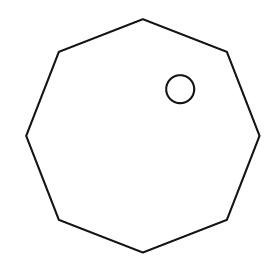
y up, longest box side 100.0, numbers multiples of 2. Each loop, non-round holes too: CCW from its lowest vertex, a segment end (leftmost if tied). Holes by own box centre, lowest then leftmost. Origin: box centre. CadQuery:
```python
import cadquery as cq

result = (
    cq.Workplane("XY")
    .moveTo(0.0, -50.0)
    .lineTo(36.0, -36.0)
    .lineTo(50.0, 0.0)
    .lineTo(36.0, 36.0)
    .lineTo(0.0, 50.0)
    .lineTo(-36.0, 36.0)
    .lineTo(-50.0, 0.0)
    .lineTo(-36.0, -36.0)
    .close()
    .moveTo(16.0, 20.0)
    .circle(6.0)
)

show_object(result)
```